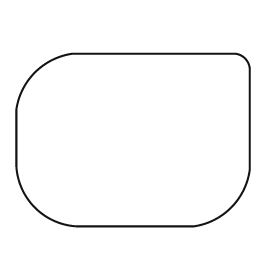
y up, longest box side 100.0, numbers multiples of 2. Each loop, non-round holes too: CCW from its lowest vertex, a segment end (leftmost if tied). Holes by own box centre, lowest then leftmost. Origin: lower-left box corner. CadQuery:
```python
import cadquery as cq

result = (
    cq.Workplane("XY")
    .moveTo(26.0, 0.0)
    .lineTo(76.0, 0.0)
    .threePointArc((92.0, 8.0), (100.0, 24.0))
    .lineTo(100.0, 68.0)
    .threePointArc((98.0, 72.0), (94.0, 74.0))
    .lineTo(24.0, 74.0)
    .threePointArc((8.0, 66.0), (0.0, 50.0))
    .lineTo(0.0, 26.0)
    .threePointArc((8.0, 8.0), (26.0, 0.0))
    .close()
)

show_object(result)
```